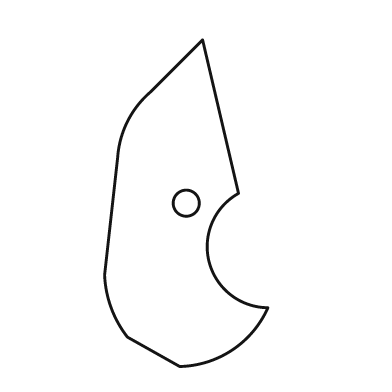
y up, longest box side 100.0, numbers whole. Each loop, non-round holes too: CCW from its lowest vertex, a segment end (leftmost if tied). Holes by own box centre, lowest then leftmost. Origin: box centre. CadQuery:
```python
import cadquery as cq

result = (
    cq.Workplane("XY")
    .moveTo(-2.0, -50.0)
    .threePointArc((14.0, -45.0), (25.0, -32.0))
    .threePointArc((7.0, -18.0), (16.0, 3.0))
    .lineTo(5.0, 50.0)
    .lineTo(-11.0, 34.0)
    .threePointArc((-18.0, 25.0), (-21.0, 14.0))
    .lineTo(-25.0, -22.0)
    .threePointArc((-23.0, -32.0), (-18.0, -41.0))
    .close()
    .moveTo(0.0, 0.0)
    .circle(4.0)
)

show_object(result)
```